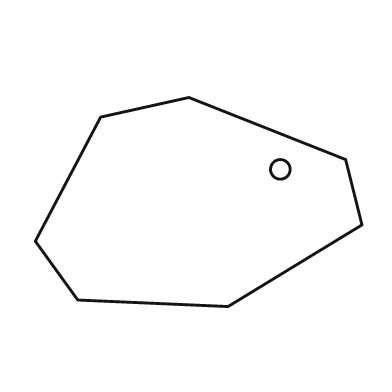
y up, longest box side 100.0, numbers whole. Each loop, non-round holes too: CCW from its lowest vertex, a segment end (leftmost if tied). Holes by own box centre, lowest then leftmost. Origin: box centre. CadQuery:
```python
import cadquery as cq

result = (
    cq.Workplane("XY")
    .moveTo(9.0, -32.0)
    .lineTo(50.0, -7.0)
    .lineTo(45.0, 13.0)
    .lineTo(-3.0, 32.0)
    .lineTo(-30.0, 26.0)
    .lineTo(-50.0, -12.0)
    .lineTo(-37.0, -30.0)
    .close()
    .moveTo(25.0, 10.0)
    .circle(3.0)
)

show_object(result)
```